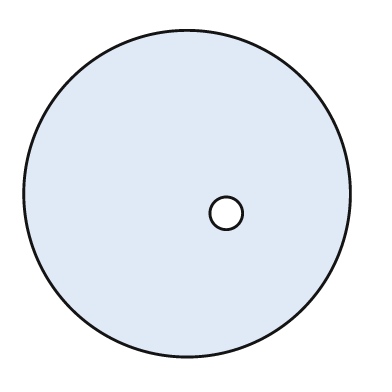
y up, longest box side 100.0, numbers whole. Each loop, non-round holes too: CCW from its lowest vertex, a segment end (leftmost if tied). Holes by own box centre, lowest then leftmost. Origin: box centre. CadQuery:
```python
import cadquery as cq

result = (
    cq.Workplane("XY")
    .moveTo(0.0, 0.0)
    .circle(50.0)
    .moveTo(12.0, -6.0)
    .circle(5.0)
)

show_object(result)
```